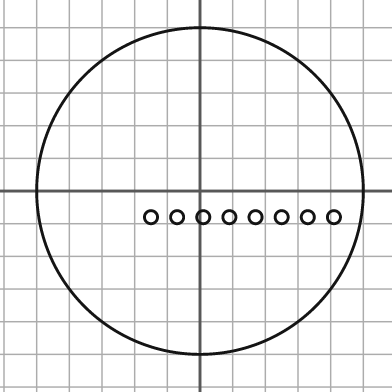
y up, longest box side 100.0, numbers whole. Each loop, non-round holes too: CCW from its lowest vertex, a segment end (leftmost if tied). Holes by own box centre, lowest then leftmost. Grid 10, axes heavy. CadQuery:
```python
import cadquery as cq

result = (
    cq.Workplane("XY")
    .moveTo(0.0, 0.0)
    .circle(50.0)
    .moveTo(-15.0, -8.0)
    .circle(2.0)
    .moveTo(-7.0, -8.0)
    .circle(2.0)
    .moveTo(1.0, -8.0)
    .circle(2.0)
    .moveTo(9.0, -8.0)
    .circle(2.0)
    .moveTo(17.0, -8.0)
    .circle(2.0)
    .moveTo(25.0, -8.0)
    .circle(2.0)
    .moveTo(33.0, -8.0)
    .circle(2.0)
    .moveTo(41.0, -8.0)
    .circle(2.0)
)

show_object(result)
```